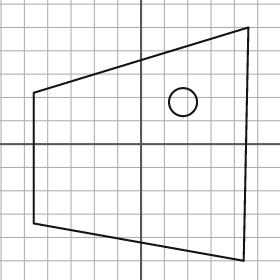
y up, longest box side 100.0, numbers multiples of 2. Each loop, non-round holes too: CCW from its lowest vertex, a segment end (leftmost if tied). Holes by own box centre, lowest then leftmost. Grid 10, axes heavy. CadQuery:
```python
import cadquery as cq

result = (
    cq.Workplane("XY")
    .moveTo(44.0, -50.0)
    .lineTo(46.0, 50.0)
    .lineTo(-46.0, 22.0)
    .lineTo(-46.0, -34.0)
    .close()
    .moveTo(18.0, 18.0)
    .circle(6.0)
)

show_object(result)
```